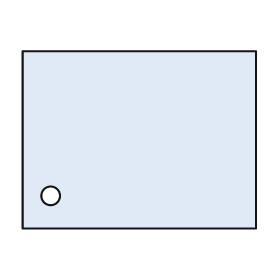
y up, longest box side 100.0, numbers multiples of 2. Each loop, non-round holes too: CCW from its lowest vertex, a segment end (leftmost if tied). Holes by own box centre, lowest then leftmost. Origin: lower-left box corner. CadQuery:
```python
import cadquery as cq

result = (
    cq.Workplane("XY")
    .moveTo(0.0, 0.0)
    .lineTo(100.0, 0.0)
    .lineTo(100.0, 76.0)
    .lineTo(0.0, 76.0)
    .close()
    .moveTo(12.0, 14.0)
    .circle(4.0)
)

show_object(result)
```